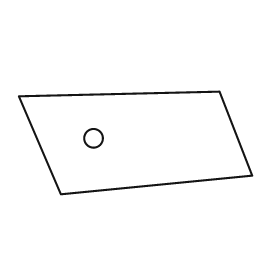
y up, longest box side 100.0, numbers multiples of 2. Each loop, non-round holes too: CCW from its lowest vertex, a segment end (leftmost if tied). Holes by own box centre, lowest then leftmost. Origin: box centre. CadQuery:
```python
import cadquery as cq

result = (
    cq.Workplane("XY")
    .moveTo(-32.0, -22.0)
    .lineTo(50.0, -14.0)
    .lineTo(36.0, 22.0)
    .lineTo(-50.0, 20.0)
    .close()
    .moveTo(-18.0, 2.0)
    .circle(4.0)
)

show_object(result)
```